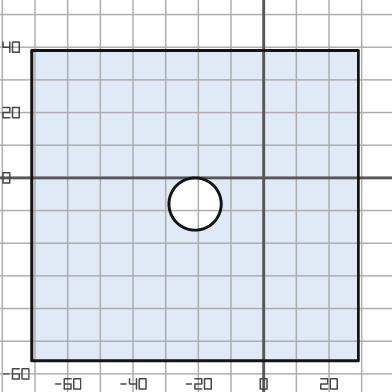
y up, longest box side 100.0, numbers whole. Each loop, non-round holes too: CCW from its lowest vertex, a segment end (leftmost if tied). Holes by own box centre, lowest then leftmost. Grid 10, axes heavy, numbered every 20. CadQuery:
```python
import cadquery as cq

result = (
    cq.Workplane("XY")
    .moveTo(-71.0, -56.0)
    .lineTo(29.0, -56.0)
    .lineTo(29.0, 39.0)
    .lineTo(-71.0, 39.0)
    .close()
    .moveTo(-21.0, -8.0)
    .circle(8.0)
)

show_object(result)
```